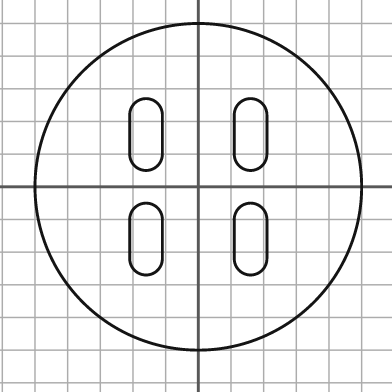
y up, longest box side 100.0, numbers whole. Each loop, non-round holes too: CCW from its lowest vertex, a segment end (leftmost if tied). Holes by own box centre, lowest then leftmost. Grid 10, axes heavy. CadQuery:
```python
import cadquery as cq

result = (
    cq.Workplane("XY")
    .moveTo(0.0, 0.0)
    .circle(50.0)
    .moveTo(-21.0, -22.0)
    .threePointArc((-16.0, -27.0), (-11.0, -22.0))
    .lineTo(-11.0, -10.0)
    .threePointArc((-16.0, -5.0), (-21.0, -10.0))
    .close()
    .moveTo(11.0, -22.0)
    .threePointArc((16.0, -27.0), (21.0, -22.0))
    .lineTo(21.0, -10.0)
    .threePointArc((16.0, -5.0), (11.0, -10.0))
    .close()
    .moveTo(-21.0, 10.0)
    .threePointArc((-16.0, 5.0), (-11.0, 10.0))
    .lineTo(-11.0, 22.0)
    .threePointArc((-16.0, 27.0), (-21.0, 22.0))
    .close()
    .moveTo(11.0, 10.0)
    .threePointArc((16.0, 5.0), (21.0, 10.0))
    .lineTo(21.0, 22.0)
    .threePointArc((16.0, 27.0), (11.0, 22.0))
    .close()
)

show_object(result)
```